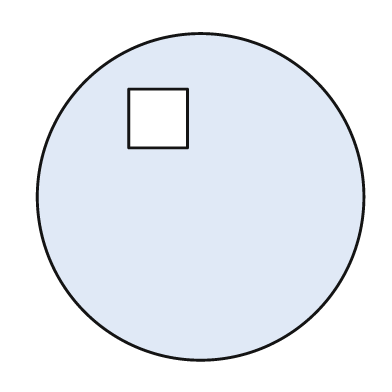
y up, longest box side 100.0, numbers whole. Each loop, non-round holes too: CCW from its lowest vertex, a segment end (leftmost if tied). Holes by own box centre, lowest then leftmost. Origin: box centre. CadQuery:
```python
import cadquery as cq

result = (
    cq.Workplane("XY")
    .moveTo(0.0, 0.0)
    .circle(50.0)
    .moveTo(-22.0, 15.0)
    .lineTo(-4.0, 15.0)
    .lineTo(-4.0, 33.0)
    .lineTo(-22.0, 33.0)
    .close()
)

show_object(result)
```